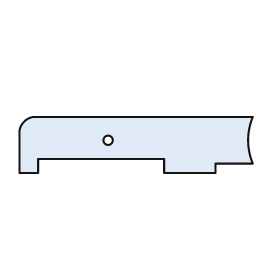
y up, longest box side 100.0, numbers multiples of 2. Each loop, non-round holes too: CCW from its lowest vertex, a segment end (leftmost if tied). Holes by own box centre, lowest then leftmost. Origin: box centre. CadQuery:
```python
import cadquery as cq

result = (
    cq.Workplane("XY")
    .moveTo(-50.0, -12.0)
    .lineTo(-42.0, -12.0)
    .lineTo(-42.0, -6.0)
    .lineTo(12.0, -6.0)
    .lineTo(12.0, -12.0)
    .lineTo(34.0, -12.0)
    .lineTo(34.0, -8.0)
    .lineTo(50.0, -8.0)
    .threePointArc((48.0, 2.0), (50.0, 12.0))
    .lineTo(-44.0, 12.0)
    .threePointArc((-48.0, 10.0), (-50.0, 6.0))
    .close()
    .moveTo(-12.0, 2.0)
    .circle(2.0)
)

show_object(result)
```